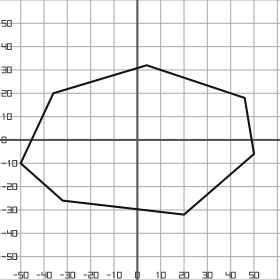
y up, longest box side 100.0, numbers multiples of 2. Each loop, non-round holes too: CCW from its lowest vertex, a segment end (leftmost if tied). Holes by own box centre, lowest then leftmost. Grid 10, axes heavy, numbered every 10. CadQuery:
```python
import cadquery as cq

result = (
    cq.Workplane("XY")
    .moveTo(20.0, -32.0)
    .lineTo(50.0, -6.0)
    .lineTo(46.0, 18.0)
    .lineTo(4.0, 32.0)
    .lineTo(-36.0, 20.0)
    .lineTo(-50.0, -10.0)
    .lineTo(-32.0, -26.0)
    .close()
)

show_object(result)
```